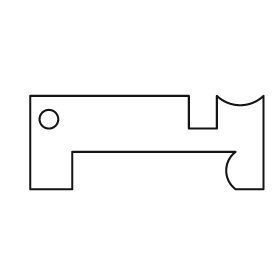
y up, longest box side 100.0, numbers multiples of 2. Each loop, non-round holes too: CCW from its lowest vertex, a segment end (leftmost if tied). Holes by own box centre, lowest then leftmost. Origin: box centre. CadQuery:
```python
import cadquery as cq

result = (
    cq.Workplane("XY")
    .moveTo(-50.0, -20.0)
    .lineTo(-32.0, -20.0)
    .lineTo(-32.0, -4.0)
    .lineTo(38.0, -4.0)
    .threePointArc((34.0, -12.0), (38.0, -20.0))
    .lineTo(50.0, -20.0)
    .lineTo(50.0, 20.0)
    .threePointArc((40.0, 16.0), (30.0, 20.0))
    .lineTo(30.0, 6.0)
    .lineTo(18.0, 6.0)
    .lineTo(18.0, 20.0)
    .lineTo(-50.0, 20.0)
    .close()
    .moveTo(-42.0, 10.0)
    .circle(4.0)
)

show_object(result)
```